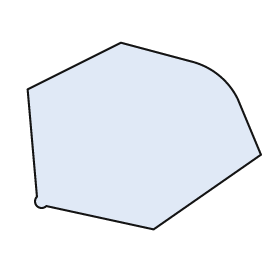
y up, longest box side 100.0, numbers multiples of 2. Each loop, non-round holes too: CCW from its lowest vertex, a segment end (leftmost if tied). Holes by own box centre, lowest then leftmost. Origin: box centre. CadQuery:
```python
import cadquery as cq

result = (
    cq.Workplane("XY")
    .moveTo(4.0, -40.0)
    .lineTo(50.0, -8.0)
    .lineTo(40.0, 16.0)
    .threePointArc((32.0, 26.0), (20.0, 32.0))
    .lineTo(-10.0, 40.0)
    .lineTo(-50.0, 20.0)
    .lineTo(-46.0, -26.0)
    .threePointArc((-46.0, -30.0), (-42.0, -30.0))
    .close()
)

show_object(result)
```